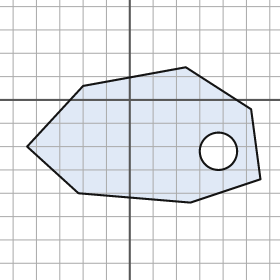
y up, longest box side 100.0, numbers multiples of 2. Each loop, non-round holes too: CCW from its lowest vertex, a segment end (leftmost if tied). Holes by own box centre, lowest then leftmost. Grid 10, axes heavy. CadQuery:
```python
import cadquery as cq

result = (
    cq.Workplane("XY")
    .moveTo(26.0, -44.0)
    .lineTo(56.0, -34.0)
    .lineTo(52.0, -4.0)
    .lineTo(24.0, 14.0)
    .lineTo(-20.0, 6.0)
    .lineTo(-44.0, -20.0)
    .lineTo(-22.0, -40.0)
    .close()
    .moveTo(38.0, -22.0)
    .circle(8.0)
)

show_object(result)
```